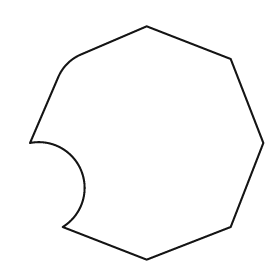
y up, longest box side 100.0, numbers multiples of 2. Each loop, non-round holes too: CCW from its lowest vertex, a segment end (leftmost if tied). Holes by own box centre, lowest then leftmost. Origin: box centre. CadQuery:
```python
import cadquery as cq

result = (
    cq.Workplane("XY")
    .moveTo(0.0, -50.0)
    .lineTo(36.0, -36.0)
    .lineTo(50.0, 0.0)
    .lineTo(36.0, 36.0)
    .lineTo(0.0, 50.0)
    .lineTo(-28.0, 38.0)
    .threePointArc((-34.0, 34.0), (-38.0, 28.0))
    .lineTo(-50.0, 0.0)
    .threePointArc((-28.0, -12.0), (-36.0, -36.0))
    .close()
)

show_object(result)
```